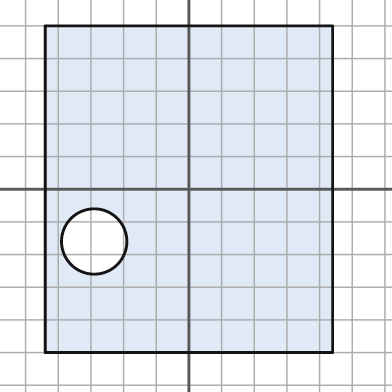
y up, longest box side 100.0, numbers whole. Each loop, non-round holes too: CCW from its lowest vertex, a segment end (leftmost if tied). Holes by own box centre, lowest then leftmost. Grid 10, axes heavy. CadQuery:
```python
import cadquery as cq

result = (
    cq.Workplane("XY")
    .moveTo(-44.0, -50.0)
    .lineTo(44.0, -50.0)
    .lineTo(44.0, 50.0)
    .lineTo(-44.0, 50.0)
    .close()
    .moveTo(-29.0, -16.0)
    .circle(10.0)
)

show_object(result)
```